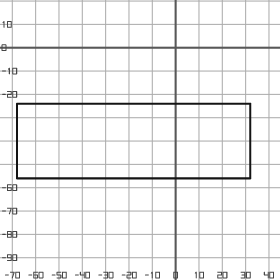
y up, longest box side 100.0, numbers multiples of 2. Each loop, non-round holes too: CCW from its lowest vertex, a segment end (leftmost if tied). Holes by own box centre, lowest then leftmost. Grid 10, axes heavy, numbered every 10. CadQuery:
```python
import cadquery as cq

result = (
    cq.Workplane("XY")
    .moveTo(-68.0, -56.0)
    .lineTo(32.0, -56.0)
    .lineTo(32.0, -24.0)
    .lineTo(-68.0, -24.0)
    .close()
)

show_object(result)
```